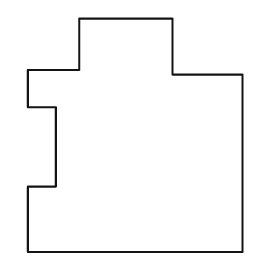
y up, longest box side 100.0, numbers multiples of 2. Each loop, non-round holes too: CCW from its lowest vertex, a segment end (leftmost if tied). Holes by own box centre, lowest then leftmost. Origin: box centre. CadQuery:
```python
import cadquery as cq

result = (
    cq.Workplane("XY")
    .moveTo(-46.0, -50.0)
    .lineTo(46.0, -50.0)
    .lineTo(46.0, 26.0)
    .lineTo(16.0, 26.0)
    .lineTo(16.0, 50.0)
    .lineTo(-24.0, 50.0)
    .lineTo(-24.0, 28.0)
    .lineTo(-46.0, 28.0)
    .lineTo(-46.0, 12.0)
    .lineTo(-34.0, 12.0)
    .lineTo(-34.0, -22.0)
    .lineTo(-46.0, -22.0)
    .close()
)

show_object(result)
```